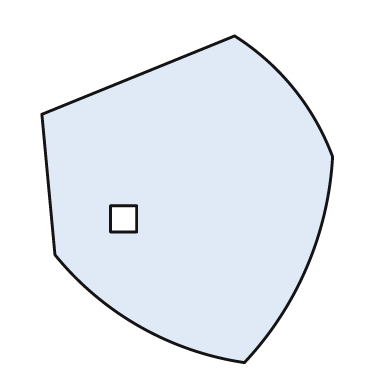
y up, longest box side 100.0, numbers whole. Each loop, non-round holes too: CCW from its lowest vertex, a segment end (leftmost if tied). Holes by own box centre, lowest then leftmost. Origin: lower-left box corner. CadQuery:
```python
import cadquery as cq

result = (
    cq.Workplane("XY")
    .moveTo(62.0, 0.0)
    .threePointArc((81.0, 29.0), (89.0, 63.0))
    .threePointArc((77.0, 84.0), (59.0, 100.0))
    .lineTo(0.0, 76.0)
    .lineTo(4.0, 33.0)
    .threePointArc((30.0, 11.0), (62.0, 0.0))
    .close()
    .moveTo(21.0, 40.0)
    .lineTo(29.0, 40.0)
    .lineTo(29.0, 48.0)
    .lineTo(21.0, 48.0)
    .close()
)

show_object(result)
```